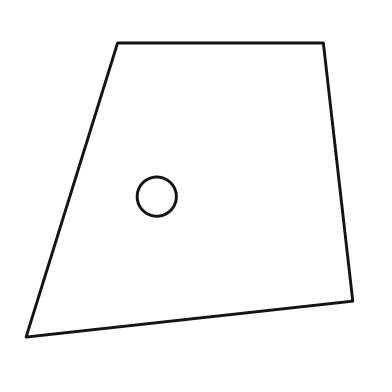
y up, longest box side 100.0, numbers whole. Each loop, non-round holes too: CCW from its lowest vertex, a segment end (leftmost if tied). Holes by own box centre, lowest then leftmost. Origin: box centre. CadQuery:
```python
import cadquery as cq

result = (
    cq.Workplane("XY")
    .moveTo(-50.0, -45.0)
    .lineTo(50.0, -34.0)
    .lineTo(41.0, 45.0)
    .lineTo(-22.0, 45.0)
    .close()
    .moveTo(-10.0, -2.0)
    .circle(6.0)
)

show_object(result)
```